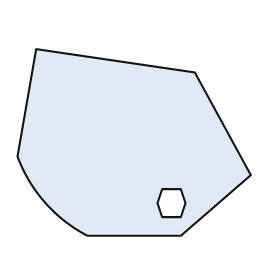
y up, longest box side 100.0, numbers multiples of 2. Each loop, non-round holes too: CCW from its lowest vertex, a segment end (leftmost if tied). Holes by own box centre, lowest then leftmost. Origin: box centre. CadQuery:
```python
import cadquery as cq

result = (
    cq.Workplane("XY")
    .moveTo(-20.0, -40.0)
    .lineTo(20.0, -40.0)
    .lineTo(50.0, -14.0)
    .lineTo(26.0, 30.0)
    .lineTo(-42.0, 40.0)
    .lineTo(-50.0, -6.0)
    .threePointArc((-38.0, -26.0), (-20.0, -40.0))
    .close()
    .moveTo(12.0, -32.0)
    .lineTo(20.0, -32.0)
    .lineTo(22.0, -26.0)
    .lineTo(20.0, -20.0)
    .lineTo(12.0, -20.0)
    .lineTo(10.0, -26.0)
    .close()
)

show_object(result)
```